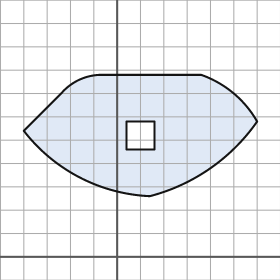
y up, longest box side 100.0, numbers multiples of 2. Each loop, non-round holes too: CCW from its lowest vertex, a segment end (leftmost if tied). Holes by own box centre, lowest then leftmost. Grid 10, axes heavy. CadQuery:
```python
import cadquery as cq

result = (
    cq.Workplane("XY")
    .moveTo(14.0, 26.0)
    .threePointArc((40.0, 38.0), (60.0, 58.0))
    .threePointArc((50.0, 70.0), (36.0, 78.0))
    .lineTo(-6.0, 78.0)
    .threePointArc((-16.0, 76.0), (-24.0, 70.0))
    .lineTo(-40.0, 54.0)
    .threePointArc((-16.0, 34.0), (14.0, 26.0))
    .close()
    .moveTo(4.0, 46.0)
    .lineTo(16.0, 46.0)
    .lineTo(16.0, 58.0)
    .lineTo(4.0, 58.0)
    .close()
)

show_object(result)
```